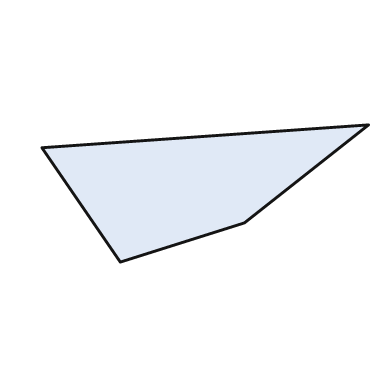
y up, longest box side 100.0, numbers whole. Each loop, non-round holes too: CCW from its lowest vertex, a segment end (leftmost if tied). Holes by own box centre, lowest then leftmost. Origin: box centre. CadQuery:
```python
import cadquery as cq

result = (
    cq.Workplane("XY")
    .moveTo(-26.0, -21.0)
    .lineTo(12.0, -9.0)
    .lineTo(50.0, 21.0)
    .lineTo(-50.0, 14.0)
    .close()
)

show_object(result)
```